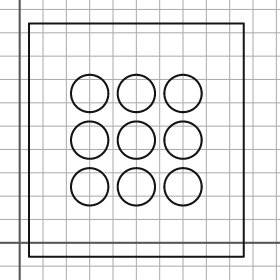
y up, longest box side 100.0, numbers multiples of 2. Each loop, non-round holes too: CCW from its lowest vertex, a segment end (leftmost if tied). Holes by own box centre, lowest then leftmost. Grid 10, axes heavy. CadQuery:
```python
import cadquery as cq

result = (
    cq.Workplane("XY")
    .moveTo(4.0, -6.0)
    .lineTo(96.0, -6.0)
    .lineTo(96.0, 94.0)
    .lineTo(4.0, 94.0)
    .close()
    .moveTo(30.0, 24.0)
    .circle(8.0)
    .moveTo(50.0, 24.0)
    .circle(8.0)
    .moveTo(70.0, 24.0)
    .circle(8.0)
    .moveTo(30.0, 44.0)
    .circle(8.0)
    .moveTo(50.0, 44.0)
    .circle(8.0)
    .moveTo(70.0, 44.0)
    .circle(8.0)
    .moveTo(30.0, 64.0)
    .circle(8.0)
    .moveTo(50.0, 64.0)
    .circle(8.0)
    .moveTo(70.0, 64.0)
    .circle(8.0)
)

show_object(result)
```